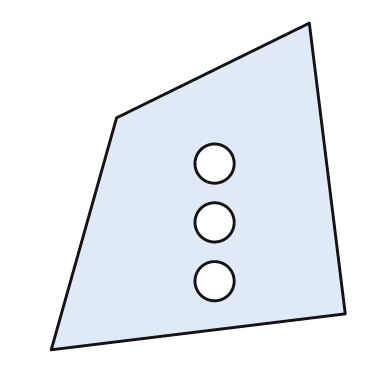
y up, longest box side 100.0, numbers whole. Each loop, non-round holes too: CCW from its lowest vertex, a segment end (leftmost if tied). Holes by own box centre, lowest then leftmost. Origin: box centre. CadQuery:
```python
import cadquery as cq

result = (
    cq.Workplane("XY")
    .moveTo(-45.0, -50.0)
    .lineTo(45.0, -39.0)
    .lineTo(34.0, 50.0)
    .lineTo(-25.0, 21.0)
    .close()
    .moveTo(5.0, -29.0)
    .circle(6.0)
    .moveTo(5.0, -11.0)
    .circle(6.0)
    .moveTo(5.0, 7.0)
    .circle(6.0)
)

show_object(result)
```